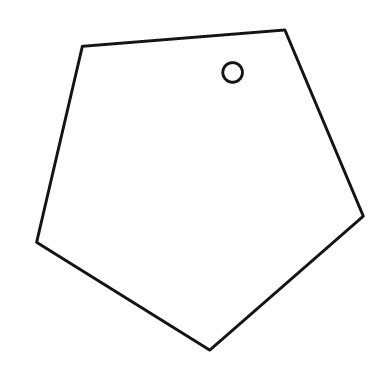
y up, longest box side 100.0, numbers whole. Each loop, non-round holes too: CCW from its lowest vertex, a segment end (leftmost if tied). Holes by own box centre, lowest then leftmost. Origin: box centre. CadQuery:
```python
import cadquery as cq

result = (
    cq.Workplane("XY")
    .moveTo(3.0, -49.0)
    .lineTo(50.0, -8.0)
    .lineTo(26.0, 49.0)
    .lineTo(-36.0, 44.0)
    .lineTo(-50.0, -16.0)
    .close()
    .moveTo(10.0, 36.0)
    .circle(3.0)
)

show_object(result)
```